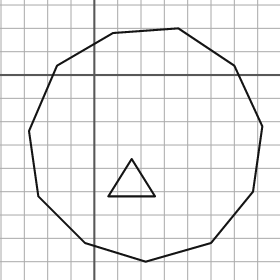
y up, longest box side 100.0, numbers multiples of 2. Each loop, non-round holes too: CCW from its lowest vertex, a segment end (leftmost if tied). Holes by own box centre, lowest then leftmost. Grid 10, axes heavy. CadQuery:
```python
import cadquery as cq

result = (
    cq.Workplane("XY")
    .moveTo(22.0, -80.0)
    .lineTo(50.0, -72.0)
    .lineTo(68.0, -50.0)
    .lineTo(72.0, -22.0)
    .lineTo(60.0, 4.0)
    .lineTo(36.0, 20.0)
    .lineTo(8.0, 18.0)
    .lineTo(-16.0, 4.0)
    .lineTo(-28.0, -24.0)
    .lineTo(-24.0, -52.0)
    .lineTo(-4.0, -72.0)
    .close()
    .moveTo(6.0, -52.0)
    .lineTo(26.0, -52.0)
    .lineTo(16.0, -36.0)
    .close()
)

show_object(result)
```